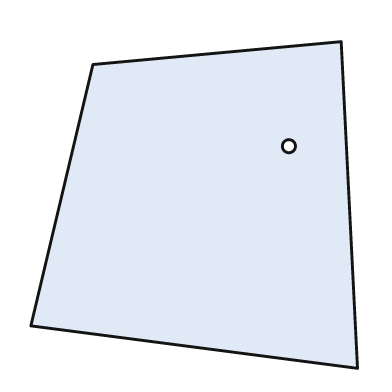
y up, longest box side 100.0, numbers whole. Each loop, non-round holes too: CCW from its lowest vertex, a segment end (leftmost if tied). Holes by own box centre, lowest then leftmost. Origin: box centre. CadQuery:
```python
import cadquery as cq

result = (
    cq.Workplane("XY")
    .moveTo(50.0, -50.0)
    .lineTo(45.0, 50.0)
    .lineTo(-31.0, 43.0)
    .lineTo(-50.0, -37.0)
    .close()
    .moveTo(29.0, 18.0)
    .circle(2.0)
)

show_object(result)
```